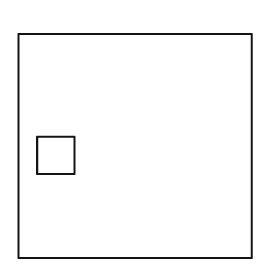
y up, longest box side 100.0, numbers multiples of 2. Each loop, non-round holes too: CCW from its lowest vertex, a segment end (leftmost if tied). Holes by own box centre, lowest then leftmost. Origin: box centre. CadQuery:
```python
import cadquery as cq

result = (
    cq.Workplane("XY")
    .moveTo(-50.0, -48.0)
    .lineTo(50.0, -48.0)
    .lineTo(50.0, 48.0)
    .lineTo(-50.0, 48.0)
    .close()
    .moveTo(-42.0, -12.0)
    .lineTo(-26.0, -12.0)
    .lineTo(-26.0, 4.0)
    .lineTo(-42.0, 4.0)
    .close()
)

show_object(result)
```